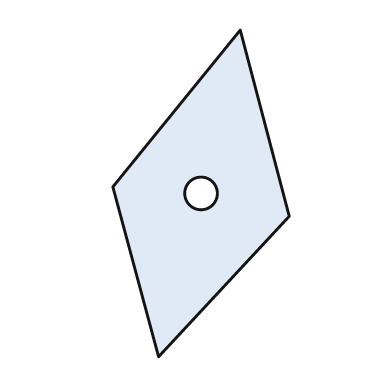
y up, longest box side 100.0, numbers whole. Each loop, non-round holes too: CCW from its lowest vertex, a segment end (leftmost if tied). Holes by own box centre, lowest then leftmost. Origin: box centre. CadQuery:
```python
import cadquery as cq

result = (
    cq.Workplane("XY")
    .moveTo(-13.0, -50.0)
    .lineTo(27.0, -7.0)
    .lineTo(12.0, 50.0)
    .lineTo(-27.0, 2.0)
    .close()
    .moveTo(0.0, 0.0)
    .circle(5.0)
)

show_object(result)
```